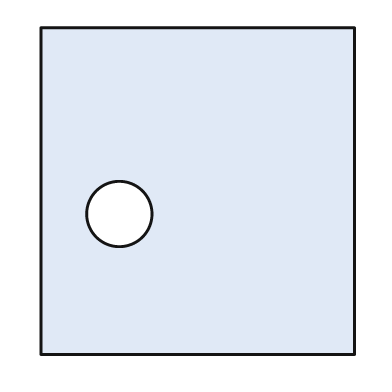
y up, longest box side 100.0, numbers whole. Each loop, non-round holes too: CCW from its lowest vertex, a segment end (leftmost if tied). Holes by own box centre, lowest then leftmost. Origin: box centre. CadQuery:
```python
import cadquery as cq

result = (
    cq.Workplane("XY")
    .moveTo(-48.0, -50.0)
    .lineTo(48.0, -50.0)
    .lineTo(48.0, 50.0)
    .lineTo(-48.0, 50.0)
    .close()
    .moveTo(-24.0, -7.0)
    .circle(10.0)
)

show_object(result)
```